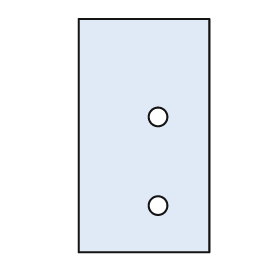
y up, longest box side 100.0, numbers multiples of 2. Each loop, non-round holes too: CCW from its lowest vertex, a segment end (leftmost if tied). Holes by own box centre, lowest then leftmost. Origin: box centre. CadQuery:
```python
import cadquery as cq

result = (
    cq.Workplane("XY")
    .moveTo(-28.0, -50.0)
    .lineTo(28.0, -50.0)
    .lineTo(28.0, 50.0)
    .lineTo(-28.0, 50.0)
    .close()
    .moveTo(6.0, -30.0)
    .circle(4.0)
    .moveTo(6.0, 8.0)
    .circle(4.0)
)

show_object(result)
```